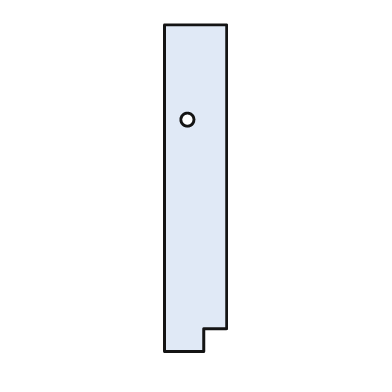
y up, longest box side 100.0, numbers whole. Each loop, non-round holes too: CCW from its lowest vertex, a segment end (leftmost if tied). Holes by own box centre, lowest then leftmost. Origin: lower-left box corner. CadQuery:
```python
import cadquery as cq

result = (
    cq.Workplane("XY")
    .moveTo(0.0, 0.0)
    .lineTo(12.0, 0.0)
    .lineTo(12.0, 7.0)
    .lineTo(19.0, 7.0)
    .lineTo(19.0, 100.0)
    .lineTo(0.0, 100.0)
    .close()
    .moveTo(7.0, 71.0)
    .circle(2.0)
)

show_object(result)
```